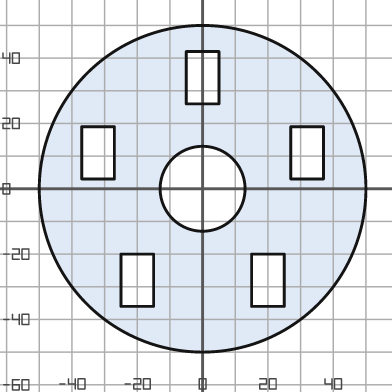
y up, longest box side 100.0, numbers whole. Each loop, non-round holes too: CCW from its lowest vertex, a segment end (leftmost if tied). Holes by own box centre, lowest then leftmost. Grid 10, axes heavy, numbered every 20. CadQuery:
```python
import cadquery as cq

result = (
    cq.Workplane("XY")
    .moveTo(0.0, 0.0)
    .circle(50.0)
    .moveTo(-25.0, -36.0)
    .lineTo(-15.0, -36.0)
    .lineTo(-15.0, -20.0)
    .lineTo(-25.0, -20.0)
    .close()
    .moveTo(15.0, -36.0)
    .lineTo(25.0, -36.0)
    .lineTo(25.0, -20.0)
    .lineTo(15.0, -20.0)
    .close()
    .moveTo(0.0, 0.0)
    .circle(13.0)
    .moveTo(-37.0, 3.0)
    .lineTo(-27.0, 3.0)
    .lineTo(-27.0, 19.0)
    .lineTo(-37.0, 19.0)
    .close()
    .moveTo(27.0, 3.0)
    .lineTo(37.0, 3.0)
    .lineTo(37.0, 19.0)
    .lineTo(27.0, 19.0)
    .close()
    .moveTo(-5.0, 26.0)
    .lineTo(5.0, 26.0)
    .lineTo(5.0, 42.0)
    .lineTo(-5.0, 42.0)
    .close()
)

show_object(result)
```